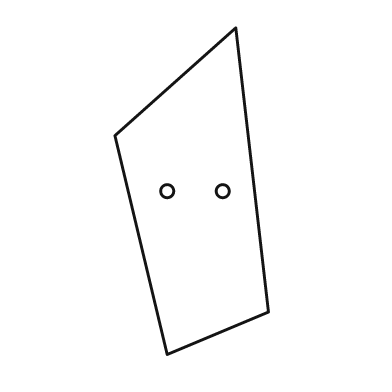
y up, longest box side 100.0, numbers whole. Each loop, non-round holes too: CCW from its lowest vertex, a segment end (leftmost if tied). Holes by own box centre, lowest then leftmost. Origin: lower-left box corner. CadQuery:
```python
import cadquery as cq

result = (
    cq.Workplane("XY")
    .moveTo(16.0, 0.0)
    .lineTo(47.0, 13.0)
    .lineTo(37.0, 100.0)
    .lineTo(0.0, 67.0)
    .close()
    .moveTo(16.0, 50.0)
    .circle(2.0)
    .moveTo(33.0, 50.0)
    .circle(2.0)
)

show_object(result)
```